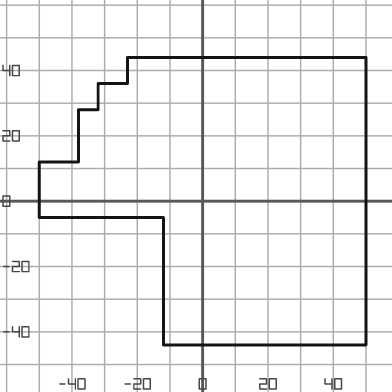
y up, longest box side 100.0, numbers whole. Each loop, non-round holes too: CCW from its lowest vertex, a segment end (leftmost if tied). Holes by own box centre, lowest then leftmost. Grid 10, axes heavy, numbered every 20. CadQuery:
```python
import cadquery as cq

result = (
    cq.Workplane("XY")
    .moveTo(-12.0, -44.0)
    .lineTo(50.0, -44.0)
    .lineTo(50.0, 44.0)
    .lineTo(-23.0, 44.0)
    .lineTo(-23.0, 36.0)
    .lineTo(-32.0, 36.0)
    .lineTo(-32.0, 28.0)
    .lineTo(-38.0, 28.0)
    .lineTo(-38.0, 12.0)
    .lineTo(-50.0, 12.0)
    .lineTo(-50.0, -5.0)
    .lineTo(-12.0, -5.0)
    .close()
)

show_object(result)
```